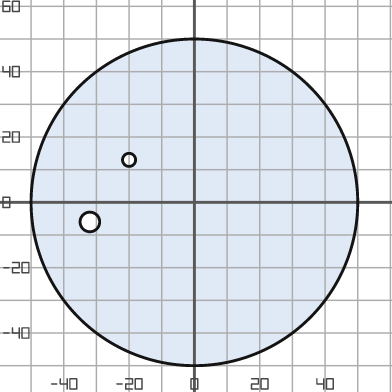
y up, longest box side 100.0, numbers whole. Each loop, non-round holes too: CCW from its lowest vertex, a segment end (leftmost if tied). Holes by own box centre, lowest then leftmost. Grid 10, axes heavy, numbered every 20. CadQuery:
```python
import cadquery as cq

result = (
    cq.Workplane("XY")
    .moveTo(0.0, 0.0)
    .circle(50.0)
    .moveTo(-32.0, -6.0)
    .circle(3.0)
    .moveTo(-20.0, 13.0)
    .circle(2.0)
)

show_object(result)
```